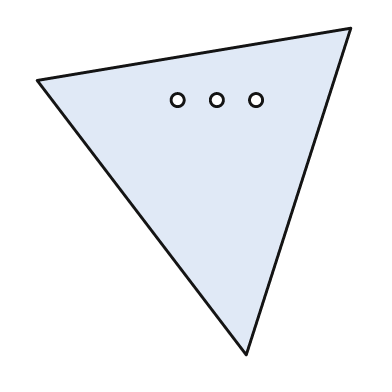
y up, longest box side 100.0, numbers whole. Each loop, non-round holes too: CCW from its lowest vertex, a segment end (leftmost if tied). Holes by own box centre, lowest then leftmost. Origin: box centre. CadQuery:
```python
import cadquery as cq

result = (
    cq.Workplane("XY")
    .moveTo(16.0, -50.0)
    .lineTo(48.0, 50.0)
    .lineTo(-48.0, 34.0)
    .close()
    .moveTo(-5.0, 28.0)
    .circle(2.0)
    .moveTo(7.0, 28.0)
    .circle(2.0)
    .moveTo(19.0, 28.0)
    .circle(2.0)
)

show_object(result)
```